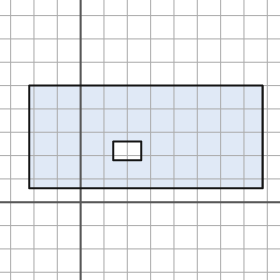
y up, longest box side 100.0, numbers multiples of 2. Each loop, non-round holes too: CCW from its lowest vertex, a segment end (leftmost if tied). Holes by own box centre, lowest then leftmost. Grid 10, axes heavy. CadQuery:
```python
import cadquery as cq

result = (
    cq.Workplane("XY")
    .moveTo(-22.0, 6.0)
    .lineTo(78.0, 6.0)
    .lineTo(78.0, 50.0)
    .lineTo(-22.0, 50.0)
    .close()
    .moveTo(14.0, 18.0)
    .lineTo(26.0, 18.0)
    .lineTo(26.0, 26.0)
    .lineTo(14.0, 26.0)
    .close()
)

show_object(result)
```